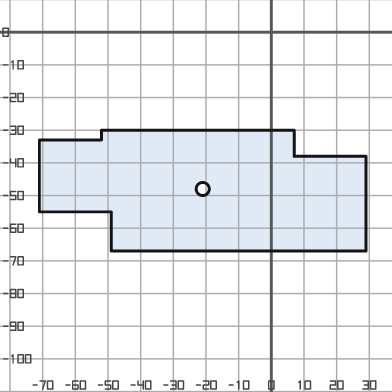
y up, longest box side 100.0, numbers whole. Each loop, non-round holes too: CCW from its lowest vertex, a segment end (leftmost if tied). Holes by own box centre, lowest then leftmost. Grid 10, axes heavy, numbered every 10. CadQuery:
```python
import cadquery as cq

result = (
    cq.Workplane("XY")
    .moveTo(-49.0, -67.0)
    .lineTo(29.0, -67.0)
    .lineTo(29.0, -38.0)
    .lineTo(7.0, -38.0)
    .lineTo(7.0, -30.0)
    .lineTo(-52.0, -30.0)
    .lineTo(-52.0, -33.0)
    .lineTo(-71.0, -33.0)
    .lineTo(-71.0, -55.0)
    .lineTo(-49.0, -55.0)
    .close()
    .moveTo(-21.0, -48.0)
    .circle(2.0)
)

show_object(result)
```